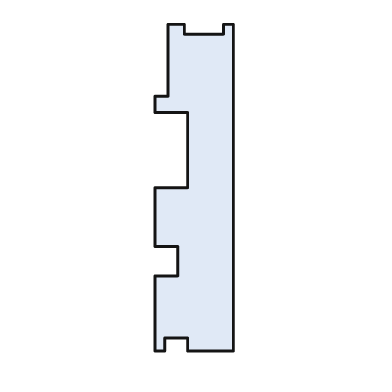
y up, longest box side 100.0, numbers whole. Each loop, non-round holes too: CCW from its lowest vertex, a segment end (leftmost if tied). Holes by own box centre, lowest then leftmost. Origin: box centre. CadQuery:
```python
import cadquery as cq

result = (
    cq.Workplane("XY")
    .moveTo(-12.0, -50.0)
    .lineTo(-9.0, -50.0)
    .lineTo(-9.0, -46.0)
    .lineTo(-2.0, -46.0)
    .lineTo(-2.0, -50.0)
    .lineTo(12.0, -50.0)
    .lineTo(12.0, 50.0)
    .lineTo(9.0, 50.0)
    .lineTo(9.0, 47.0)
    .lineTo(-3.0, 47.0)
    .lineTo(-3.0, 50.0)
    .lineTo(-8.0, 50.0)
    .lineTo(-8.0, 28.0)
    .lineTo(-12.0, 28.0)
    .lineTo(-12.0, 23.0)
    .lineTo(-2.0, 23.0)
    .lineTo(-2.0, 0.0)
    .lineTo(-12.0, 0.0)
    .lineTo(-12.0, -18.0)
    .lineTo(-5.0, -18.0)
    .lineTo(-5.0, -27.0)
    .lineTo(-12.0, -27.0)
    .close()
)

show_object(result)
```